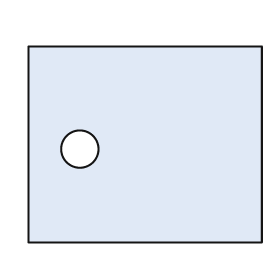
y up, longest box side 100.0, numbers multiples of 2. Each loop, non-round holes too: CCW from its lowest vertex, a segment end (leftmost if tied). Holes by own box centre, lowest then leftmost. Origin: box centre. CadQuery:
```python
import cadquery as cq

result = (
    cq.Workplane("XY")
    .moveTo(-50.0, -42.0)
    .lineTo(50.0, -42.0)
    .lineTo(50.0, 42.0)
    .lineTo(-50.0, 42.0)
    .close()
    .moveTo(-28.0, -2.0)
    .circle(8.0)
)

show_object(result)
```